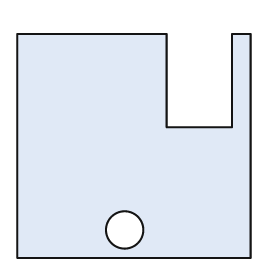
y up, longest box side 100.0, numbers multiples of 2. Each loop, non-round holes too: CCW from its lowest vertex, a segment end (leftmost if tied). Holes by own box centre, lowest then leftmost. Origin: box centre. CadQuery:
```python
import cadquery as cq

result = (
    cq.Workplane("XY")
    .moveTo(-50.0, -48.0)
    .lineTo(50.0, -48.0)
    .lineTo(50.0, 48.0)
    .lineTo(42.0, 48.0)
    .lineTo(42.0, 8.0)
    .lineTo(14.0, 8.0)
    .lineTo(14.0, 48.0)
    .lineTo(-50.0, 48.0)
    .close()
    .moveTo(-4.0, -36.0)
    .circle(8.0)
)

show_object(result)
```